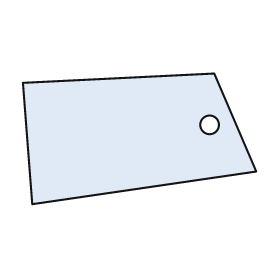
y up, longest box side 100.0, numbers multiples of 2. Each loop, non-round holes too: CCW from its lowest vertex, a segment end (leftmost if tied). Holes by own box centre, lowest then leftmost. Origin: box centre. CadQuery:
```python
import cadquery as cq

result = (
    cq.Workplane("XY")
    .moveTo(-46.0, -28.0)
    .lineTo(50.0, -14.0)
    .lineTo(32.0, 28.0)
    .lineTo(-50.0, 24.0)
    .close()
    .moveTo(30.0, 6.0)
    .circle(4.0)
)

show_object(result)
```